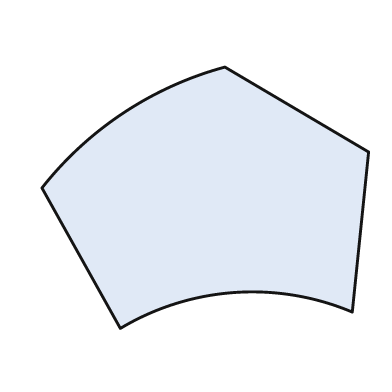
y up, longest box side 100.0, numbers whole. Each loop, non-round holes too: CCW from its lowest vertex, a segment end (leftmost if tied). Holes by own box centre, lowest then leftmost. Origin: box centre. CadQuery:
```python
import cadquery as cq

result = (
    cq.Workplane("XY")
    .moveTo(-26.0, -40.0)
    .threePointArc((9.0, -29.0), (45.0, -35.0))
    .lineTo(50.0, 14.0)
    .lineTo(6.0, 40.0)
    .threePointArc((-25.0, 26.0), (-50.0, 3.0))
    .close()
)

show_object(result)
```